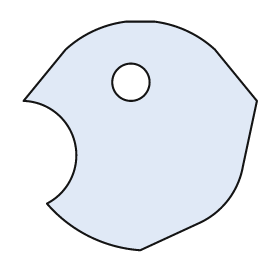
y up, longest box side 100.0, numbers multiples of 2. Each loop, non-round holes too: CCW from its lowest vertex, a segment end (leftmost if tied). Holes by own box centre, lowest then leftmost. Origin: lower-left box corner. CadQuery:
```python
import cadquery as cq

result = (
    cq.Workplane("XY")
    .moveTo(50.0, 0.0)
    .lineTo(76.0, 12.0)
    .threePointArc((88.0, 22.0), (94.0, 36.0))
    .lineTo(100.0, 64.0)
    .lineTo(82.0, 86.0)
    .threePointArc((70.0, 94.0), (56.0, 98.0))
    .lineTo(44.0, 98.0)
    .threePointArc((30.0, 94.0), (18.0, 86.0))
    .lineTo(0.0, 64.0)
    .threePointArc((22.0, 46.0), (10.0, 20.0))
    .threePointArc((28.0, 6.0), (50.0, 0.0))
    .close()
    .moveTo(46.0, 72.0)
    .circle(8.0)
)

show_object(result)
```